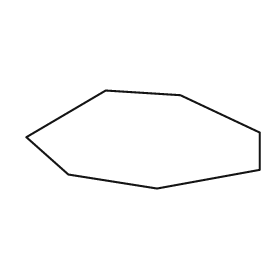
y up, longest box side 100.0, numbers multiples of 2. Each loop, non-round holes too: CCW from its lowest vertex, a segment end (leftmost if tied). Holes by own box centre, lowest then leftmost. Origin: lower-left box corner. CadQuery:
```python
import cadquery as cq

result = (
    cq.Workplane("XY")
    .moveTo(56.0, 0.0)
    .lineTo(100.0, 8.0)
    .lineTo(100.0, 24.0)
    .lineTo(66.0, 40.0)
    .lineTo(34.0, 42.0)
    .lineTo(0.0, 22.0)
    .lineTo(18.0, 6.0)
    .close()
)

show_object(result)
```